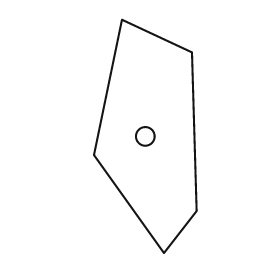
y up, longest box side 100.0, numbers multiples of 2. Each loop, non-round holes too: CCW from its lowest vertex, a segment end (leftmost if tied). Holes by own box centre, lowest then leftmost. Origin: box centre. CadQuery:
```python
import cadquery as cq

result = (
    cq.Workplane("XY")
    .moveTo(8.0, -50.0)
    .lineTo(22.0, -32.0)
    .lineTo(20.0, 36.0)
    .lineTo(-10.0, 50.0)
    .lineTo(-22.0, -8.0)
    .close()
    .moveTo(0.0, 0.0)
    .circle(4.0)
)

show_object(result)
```